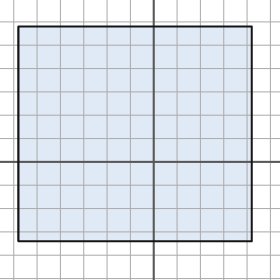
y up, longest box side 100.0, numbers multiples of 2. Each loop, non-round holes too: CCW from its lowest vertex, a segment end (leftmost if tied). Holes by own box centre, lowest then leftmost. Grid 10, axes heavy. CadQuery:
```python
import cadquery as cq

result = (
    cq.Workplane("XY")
    .moveTo(-58.0, -34.0)
    .lineTo(42.0, -34.0)
    .lineTo(42.0, 58.0)
    .lineTo(-58.0, 58.0)
    .close()
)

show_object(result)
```